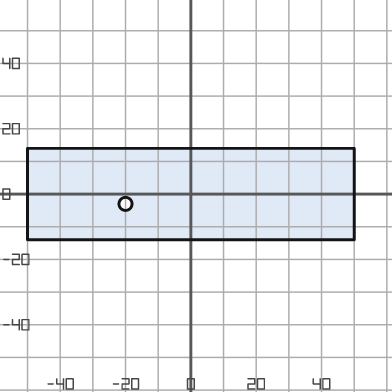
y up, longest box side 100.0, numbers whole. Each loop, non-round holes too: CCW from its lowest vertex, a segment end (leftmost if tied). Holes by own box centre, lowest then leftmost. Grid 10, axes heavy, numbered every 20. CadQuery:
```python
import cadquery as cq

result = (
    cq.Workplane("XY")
    .moveTo(-50.0, -14.0)
    .lineTo(50.0, -14.0)
    .lineTo(50.0, 14.0)
    .lineTo(-50.0, 14.0)
    .close()
    .moveTo(-20.0, -3.0)
    .circle(2.0)
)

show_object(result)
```